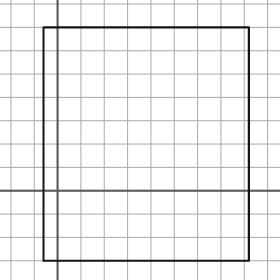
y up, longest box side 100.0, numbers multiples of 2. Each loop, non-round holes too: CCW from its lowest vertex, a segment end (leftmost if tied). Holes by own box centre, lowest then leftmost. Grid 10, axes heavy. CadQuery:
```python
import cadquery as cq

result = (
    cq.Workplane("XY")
    .moveTo(-6.0, -30.0)
    .lineTo(82.0, -30.0)
    .lineTo(82.0, 70.0)
    .lineTo(-6.0, 70.0)
    .close()
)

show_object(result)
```